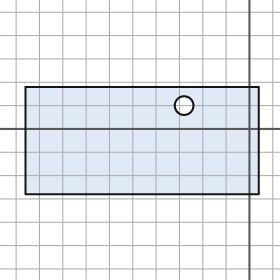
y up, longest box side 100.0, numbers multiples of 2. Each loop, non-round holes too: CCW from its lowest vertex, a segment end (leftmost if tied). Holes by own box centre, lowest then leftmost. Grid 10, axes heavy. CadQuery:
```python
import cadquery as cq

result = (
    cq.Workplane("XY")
    .moveTo(-96.0, -28.0)
    .lineTo(4.0, -28.0)
    .lineTo(4.0, 18.0)
    .lineTo(-96.0, 18.0)
    .close()
    .moveTo(-28.0, 10.0)
    .circle(4.0)
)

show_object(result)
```